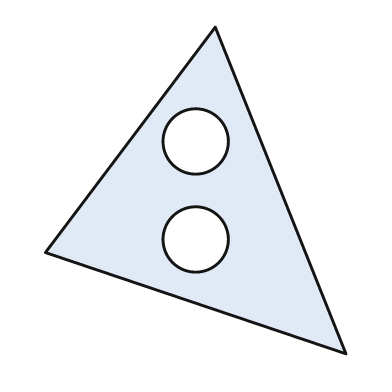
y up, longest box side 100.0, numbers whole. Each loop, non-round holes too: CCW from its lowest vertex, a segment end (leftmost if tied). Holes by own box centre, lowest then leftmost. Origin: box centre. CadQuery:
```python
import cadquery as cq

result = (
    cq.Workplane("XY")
    .moveTo(46.0, -50.0)
    .lineTo(6.0, 50.0)
    .lineTo(-46.0, -19.0)
    .close()
    .moveTo(0.0, -15.0)
    .circle(10.0)
    .moveTo(0.0, 15.0)
    .circle(10.0)
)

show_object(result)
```